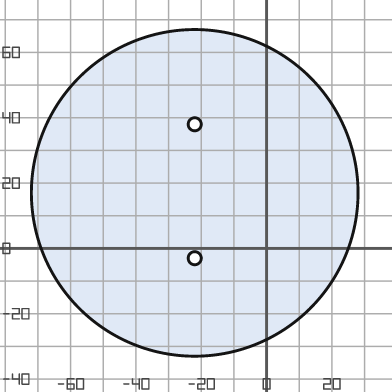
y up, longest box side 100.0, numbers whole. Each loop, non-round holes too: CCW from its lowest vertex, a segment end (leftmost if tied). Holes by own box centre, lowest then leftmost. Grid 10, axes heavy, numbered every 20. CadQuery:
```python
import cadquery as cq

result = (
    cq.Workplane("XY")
    .moveTo(-22.0, 17.0)
    .circle(50.0)
    .moveTo(-22.0, -3.0)
    .circle(2.0)
    .moveTo(-22.0, 38.0)
    .circle(2.0)
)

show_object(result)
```